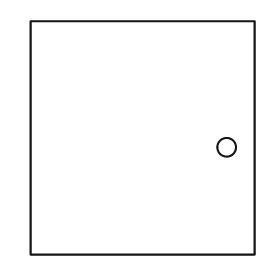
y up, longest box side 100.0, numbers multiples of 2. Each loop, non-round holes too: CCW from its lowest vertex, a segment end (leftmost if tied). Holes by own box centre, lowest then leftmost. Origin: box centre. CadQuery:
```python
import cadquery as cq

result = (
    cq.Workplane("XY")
    .moveTo(-48.0, -50.0)
    .lineTo(48.0, -50.0)
    .lineTo(48.0, 50.0)
    .lineTo(-48.0, 50.0)
    .close()
    .moveTo(36.0, -4.0)
    .circle(4.0)
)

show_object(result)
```